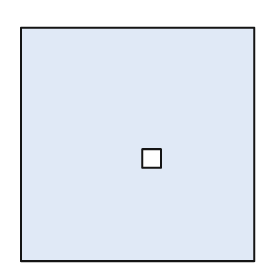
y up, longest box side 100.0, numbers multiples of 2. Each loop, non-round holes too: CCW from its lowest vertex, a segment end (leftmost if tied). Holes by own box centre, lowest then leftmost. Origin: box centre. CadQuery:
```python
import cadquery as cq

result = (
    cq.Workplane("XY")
    .moveTo(-50.0, -50.0)
    .lineTo(50.0, -50.0)
    .lineTo(50.0, 50.0)
    .lineTo(-50.0, 50.0)
    .close()
    .moveTo(2.0, -10.0)
    .lineTo(10.0, -10.0)
    .lineTo(10.0, -2.0)
    .lineTo(2.0, -2.0)
    .close()
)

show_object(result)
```